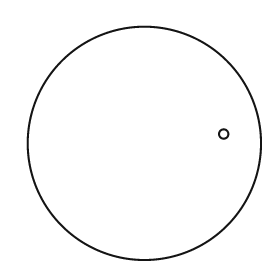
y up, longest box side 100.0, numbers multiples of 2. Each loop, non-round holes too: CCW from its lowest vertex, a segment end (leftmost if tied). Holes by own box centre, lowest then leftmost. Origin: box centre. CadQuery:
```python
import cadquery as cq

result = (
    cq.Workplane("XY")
    .moveTo(0.0, 0.0)
    .circle(50.0)
    .moveTo(34.0, 4.0)
    .circle(2.0)
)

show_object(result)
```